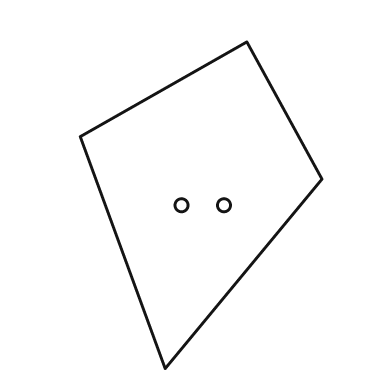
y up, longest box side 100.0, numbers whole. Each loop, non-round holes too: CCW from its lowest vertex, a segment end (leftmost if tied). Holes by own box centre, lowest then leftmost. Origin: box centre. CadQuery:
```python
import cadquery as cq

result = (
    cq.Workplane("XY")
    .moveTo(-11.0, -50.0)
    .lineTo(37.0, 8.0)
    .lineTo(14.0, 50.0)
    .lineTo(-37.0, 21.0)
    .close()
    .moveTo(-6.0, 0.0)
    .circle(2.0)
    .moveTo(7.0, 0.0)
    .circle(2.0)
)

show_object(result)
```